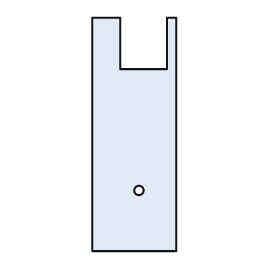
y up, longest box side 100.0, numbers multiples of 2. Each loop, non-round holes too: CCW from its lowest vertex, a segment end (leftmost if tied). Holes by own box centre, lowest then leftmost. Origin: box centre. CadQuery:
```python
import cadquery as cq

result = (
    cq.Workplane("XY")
    .moveTo(-18.0, -50.0)
    .lineTo(18.0, -50.0)
    .lineTo(18.0, 50.0)
    .lineTo(14.0, 50.0)
    .lineTo(14.0, 28.0)
    .lineTo(-6.0, 28.0)
    .lineTo(-6.0, 50.0)
    .lineTo(-18.0, 50.0)
    .close()
    .moveTo(2.0, -24.0)
    .circle(2.0)
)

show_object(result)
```